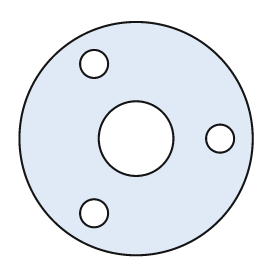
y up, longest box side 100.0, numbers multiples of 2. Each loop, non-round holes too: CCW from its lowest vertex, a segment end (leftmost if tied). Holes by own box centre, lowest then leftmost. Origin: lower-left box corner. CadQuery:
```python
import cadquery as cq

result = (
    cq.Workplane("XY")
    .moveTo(50.0, 50.0)
    .circle(50.0)
    .moveTo(32.0, 18.0)
    .circle(6.0)
    .moveTo(50.0, 50.0)
    .circle(16.0)
    .moveTo(86.0, 50.0)
    .circle(6.0)
    .moveTo(32.0, 82.0)
    .circle(6.0)
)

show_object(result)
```